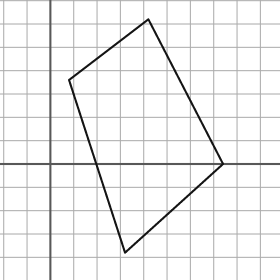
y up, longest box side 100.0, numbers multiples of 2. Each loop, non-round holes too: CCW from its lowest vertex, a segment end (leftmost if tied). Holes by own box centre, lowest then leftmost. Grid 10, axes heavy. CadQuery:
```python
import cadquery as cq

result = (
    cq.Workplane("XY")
    .moveTo(32.0, -38.0)
    .lineTo(74.0, 0.0)
    .lineTo(42.0, 62.0)
    .lineTo(8.0, 36.0)
    .close()
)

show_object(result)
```